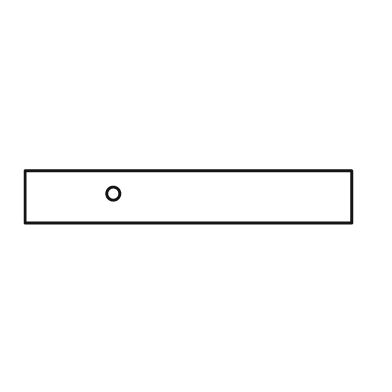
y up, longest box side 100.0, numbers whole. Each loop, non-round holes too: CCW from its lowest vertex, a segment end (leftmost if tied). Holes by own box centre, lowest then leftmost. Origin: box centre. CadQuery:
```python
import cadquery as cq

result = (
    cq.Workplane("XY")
    .moveTo(-50.0, -8.0)
    .lineTo(50.0, -8.0)
    .lineTo(50.0, 8.0)
    .lineTo(-50.0, 8.0)
    .close()
    .moveTo(-23.0, 1.0)
    .circle(2.0)
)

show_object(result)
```